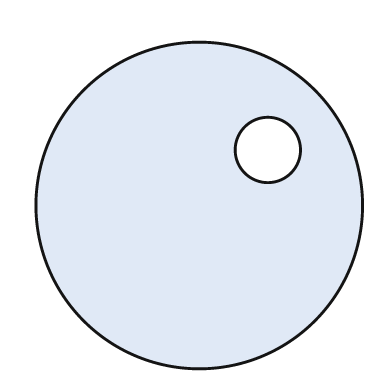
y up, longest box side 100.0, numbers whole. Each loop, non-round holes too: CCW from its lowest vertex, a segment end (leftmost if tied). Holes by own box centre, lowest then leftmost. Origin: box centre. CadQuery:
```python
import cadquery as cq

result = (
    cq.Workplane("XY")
    .moveTo(0.0, 0.0)
    .circle(50.0)
    .moveTo(21.0, 17.0)
    .circle(10.0)
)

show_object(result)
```